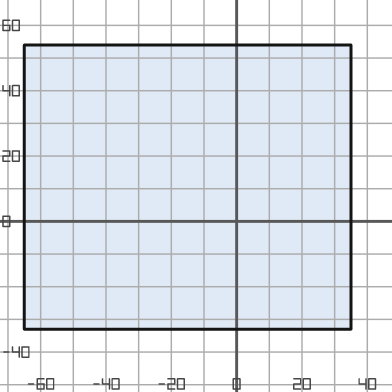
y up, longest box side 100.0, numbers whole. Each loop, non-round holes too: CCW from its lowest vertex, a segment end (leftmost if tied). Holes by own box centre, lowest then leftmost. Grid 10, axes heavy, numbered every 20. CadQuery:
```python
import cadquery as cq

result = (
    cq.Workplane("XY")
    .moveTo(-65.0, -33.0)
    .lineTo(35.0, -33.0)
    .lineTo(35.0, 54.0)
    .lineTo(-65.0, 54.0)
    .close()
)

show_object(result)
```